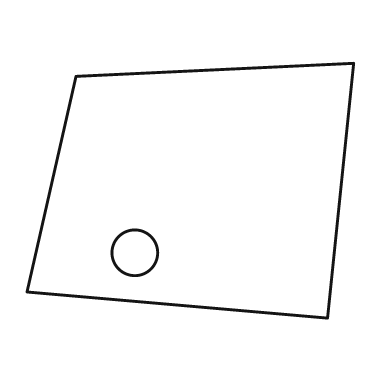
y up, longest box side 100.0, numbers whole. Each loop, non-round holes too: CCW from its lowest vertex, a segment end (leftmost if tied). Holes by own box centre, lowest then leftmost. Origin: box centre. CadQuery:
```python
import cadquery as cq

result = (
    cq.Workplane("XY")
    .moveTo(42.0, -39.0)
    .lineTo(50.0, 39.0)
    .lineTo(-35.0, 35.0)
    .lineTo(-50.0, -31.0)
    .close()
    .moveTo(-17.0, -19.0)
    .circle(7.0)
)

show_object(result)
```